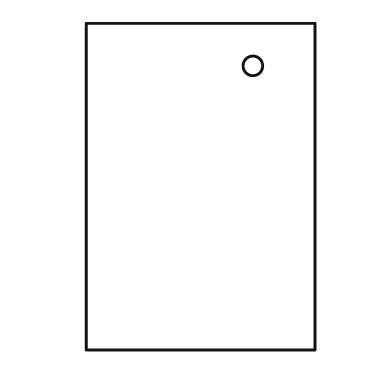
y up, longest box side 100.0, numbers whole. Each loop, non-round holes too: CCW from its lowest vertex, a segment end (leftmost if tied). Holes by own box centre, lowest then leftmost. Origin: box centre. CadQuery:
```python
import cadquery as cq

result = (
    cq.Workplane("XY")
    .moveTo(-35.0, -50.0)
    .lineTo(35.0, -50.0)
    .lineTo(35.0, 50.0)
    .lineTo(-35.0, 50.0)
    .close()
    .moveTo(16.0, 37.0)
    .circle(3.0)
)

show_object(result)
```